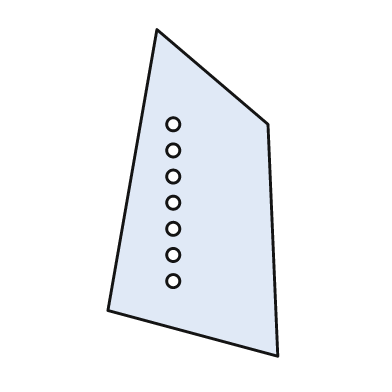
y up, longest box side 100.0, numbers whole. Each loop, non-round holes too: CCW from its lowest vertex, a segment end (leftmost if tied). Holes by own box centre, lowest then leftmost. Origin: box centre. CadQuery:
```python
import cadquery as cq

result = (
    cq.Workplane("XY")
    .moveTo(26.0, -50.0)
    .lineTo(23.0, 21.0)
    .lineTo(-11.0, 50.0)
    .lineTo(-26.0, -36.0)
    .close()
    .moveTo(-6.0, -27.0)
    .circle(2.0)
    .moveTo(-6.0, -19.0)
    .circle(2.0)
    .moveTo(-6.0, -11.0)
    .circle(2.0)
    .moveTo(-6.0, -3.0)
    .circle(2.0)
    .moveTo(-6.0, 5.0)
    .circle(2.0)
    .moveTo(-6.0, 13.0)
    .circle(2.0)
    .moveTo(-6.0, 21.0)
    .circle(2.0)
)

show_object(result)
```